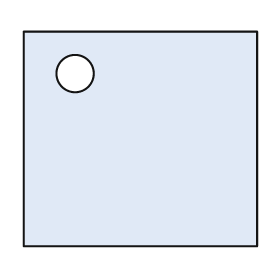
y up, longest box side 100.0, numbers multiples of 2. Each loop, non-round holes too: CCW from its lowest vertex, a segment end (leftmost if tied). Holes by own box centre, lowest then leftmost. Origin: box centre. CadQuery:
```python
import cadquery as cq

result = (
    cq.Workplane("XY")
    .moveTo(-50.0, -46.0)
    .lineTo(50.0, -46.0)
    .lineTo(50.0, 46.0)
    .lineTo(-50.0, 46.0)
    .close()
    .moveTo(-28.0, 28.0)
    .circle(8.0)
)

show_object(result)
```